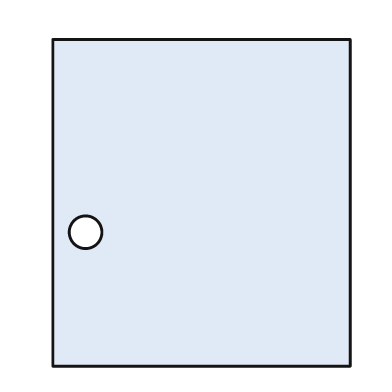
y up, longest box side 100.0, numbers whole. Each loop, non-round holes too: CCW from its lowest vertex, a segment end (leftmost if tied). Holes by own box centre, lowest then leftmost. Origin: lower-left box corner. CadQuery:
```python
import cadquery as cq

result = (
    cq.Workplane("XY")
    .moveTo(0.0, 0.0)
    .lineTo(91.0, 0.0)
    .lineTo(91.0, 100.0)
    .lineTo(0.0, 100.0)
    .close()
    .moveTo(10.0, 41.0)
    .circle(5.0)
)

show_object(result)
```